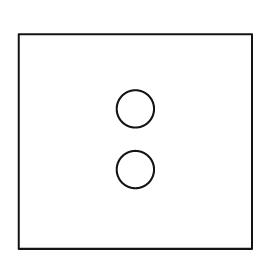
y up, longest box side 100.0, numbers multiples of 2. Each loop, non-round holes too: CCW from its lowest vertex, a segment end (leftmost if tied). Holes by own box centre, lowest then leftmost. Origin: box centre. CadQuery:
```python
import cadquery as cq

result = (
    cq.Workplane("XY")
    .moveTo(-50.0, -46.0)
    .lineTo(50.0, -46.0)
    .lineTo(50.0, 46.0)
    .lineTo(-50.0, 46.0)
    .close()
    .moveTo(0.0, -12.0)
    .circle(8.0)
    .moveTo(0.0, 14.0)
    .circle(8.0)
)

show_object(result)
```